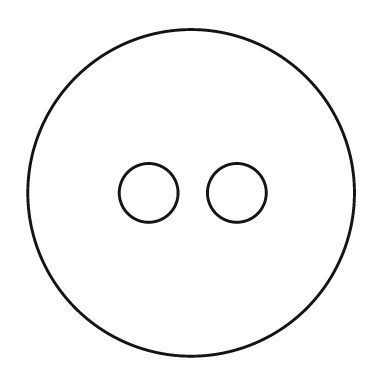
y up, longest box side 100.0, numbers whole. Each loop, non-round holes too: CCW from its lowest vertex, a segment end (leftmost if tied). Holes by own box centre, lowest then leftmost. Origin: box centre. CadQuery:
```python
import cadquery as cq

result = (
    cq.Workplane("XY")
    .moveTo(0.0, 0.0)
    .circle(50.0)
    .moveTo(-13.0, 0.0)
    .circle(9.0)
    .moveTo(14.0, 0.0)
    .circle(9.0)
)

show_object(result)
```